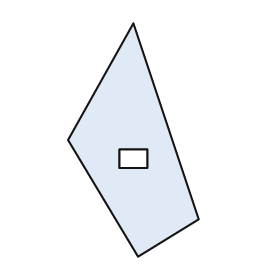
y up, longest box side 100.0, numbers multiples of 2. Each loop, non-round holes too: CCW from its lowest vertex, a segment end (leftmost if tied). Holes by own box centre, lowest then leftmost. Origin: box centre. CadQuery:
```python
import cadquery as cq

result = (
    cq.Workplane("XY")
    .moveTo(2.0, -50.0)
    .lineTo(28.0, -34.0)
    .lineTo(0.0, 50.0)
    .lineTo(-28.0, 0.0)
    .close()
    .moveTo(-6.0, -12.0)
    .lineTo(6.0, -12.0)
    .lineTo(6.0, -4.0)
    .lineTo(-6.0, -4.0)
    .close()
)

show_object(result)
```